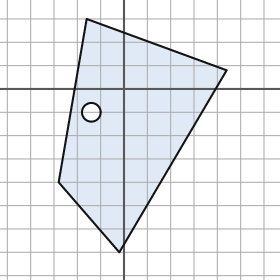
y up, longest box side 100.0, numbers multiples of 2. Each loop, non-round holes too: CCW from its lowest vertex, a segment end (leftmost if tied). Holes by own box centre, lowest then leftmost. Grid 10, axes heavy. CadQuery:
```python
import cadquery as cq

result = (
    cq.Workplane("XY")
    .moveTo(-2.0, -70.0)
    .lineTo(44.0, 8.0)
    .lineTo(-16.0, 30.0)
    .lineTo(-28.0, -40.0)
    .close()
    .moveTo(-14.0, -10.0)
    .circle(4.0)
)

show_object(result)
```